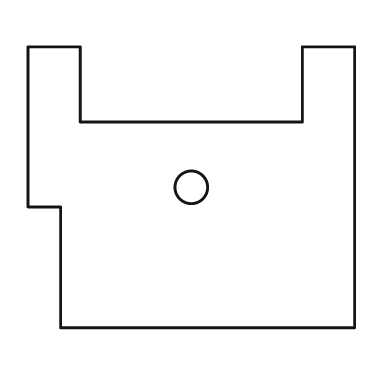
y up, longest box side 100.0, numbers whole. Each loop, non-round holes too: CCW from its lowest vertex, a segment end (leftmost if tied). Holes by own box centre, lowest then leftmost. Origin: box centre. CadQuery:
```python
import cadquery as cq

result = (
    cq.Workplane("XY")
    .moveTo(-40.0, -43.0)
    .lineTo(50.0, -43.0)
    .lineTo(50.0, 43.0)
    .lineTo(34.0, 43.0)
    .lineTo(34.0, 20.0)
    .lineTo(-34.0, 20.0)
    .lineTo(-34.0, 43.0)
    .lineTo(-50.0, 43.0)
    .lineTo(-50.0, -6.0)
    .lineTo(-40.0, -6.0)
    .close()
    .moveTo(0.0, 0.0)
    .circle(5.0)
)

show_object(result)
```